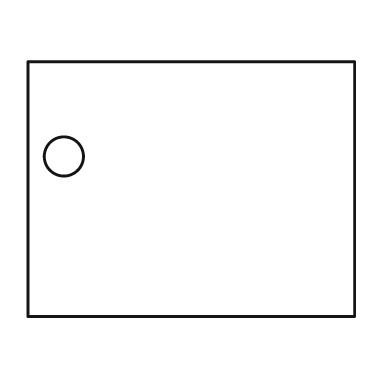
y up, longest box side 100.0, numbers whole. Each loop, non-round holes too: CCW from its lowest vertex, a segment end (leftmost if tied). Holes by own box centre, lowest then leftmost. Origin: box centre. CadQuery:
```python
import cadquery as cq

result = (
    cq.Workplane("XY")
    .moveTo(-50.0, -39.0)
    .lineTo(50.0, -39.0)
    .lineTo(50.0, 39.0)
    .lineTo(-50.0, 39.0)
    .close()
    .moveTo(-39.0, 10.0)
    .circle(6.0)
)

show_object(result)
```